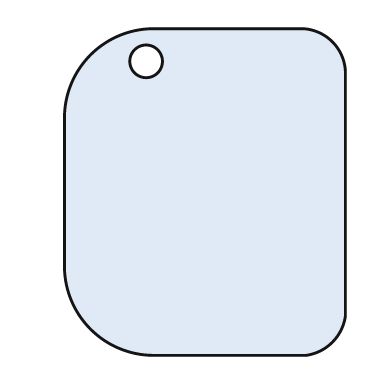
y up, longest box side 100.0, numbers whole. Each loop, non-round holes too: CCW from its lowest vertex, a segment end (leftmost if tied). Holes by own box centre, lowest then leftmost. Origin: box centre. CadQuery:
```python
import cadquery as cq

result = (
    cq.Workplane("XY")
    .moveTo(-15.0, -50.0)
    .lineTo(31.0, -50.0)
    .threePointArc((39.0, -46.0), (43.0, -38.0))
    .lineTo(43.0, 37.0)
    .threePointArc((39.0, 46.0), (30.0, 50.0))
    .lineTo(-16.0, 50.0)
    .threePointArc((-35.0, 42.0), (-43.0, 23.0))
    .lineTo(-43.0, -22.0)
    .threePointArc((-35.0, -42.0), (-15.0, -50.0))
    .close()
    .moveTo(-18.0, 40.0)
    .circle(5.0)
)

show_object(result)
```